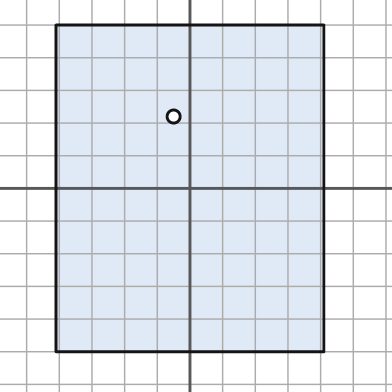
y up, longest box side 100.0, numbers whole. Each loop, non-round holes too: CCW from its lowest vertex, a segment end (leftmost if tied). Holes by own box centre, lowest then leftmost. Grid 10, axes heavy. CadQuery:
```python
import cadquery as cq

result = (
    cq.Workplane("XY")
    .moveTo(-41.0, -50.0)
    .lineTo(41.0, -50.0)
    .lineTo(41.0, 50.0)
    .lineTo(-41.0, 50.0)
    .close()
    .moveTo(-5.0, 22.0)
    .circle(2.0)
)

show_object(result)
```